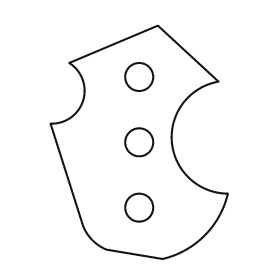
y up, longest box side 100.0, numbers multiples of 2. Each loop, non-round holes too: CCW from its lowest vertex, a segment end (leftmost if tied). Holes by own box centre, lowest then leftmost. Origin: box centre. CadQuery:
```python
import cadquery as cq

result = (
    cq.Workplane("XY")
    .moveTo(10.0, -50.0)
    .threePointArc((28.0, -40.0), (38.0, -22.0))
    .threePointArc((14.0, 0.0), (34.0, 26.0))
    .lineTo(8.0, 50.0)
    .lineTo(-30.0, 34.0)
    .threePointArc((-24.0, 18.0), (-38.0, 8.0))
    .lineTo(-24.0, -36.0)
    .threePointArc((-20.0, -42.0), (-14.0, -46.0))
    .close()
    .moveTo(0.0, -28.0)
    .circle(6.0)
    .moveTo(0.0, 0.0)
    .circle(6.0)
    .moveTo(0.0, 28.0)
    .circle(6.0)
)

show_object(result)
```